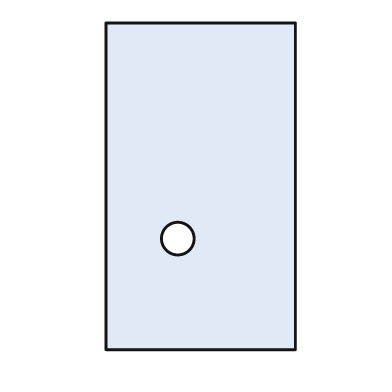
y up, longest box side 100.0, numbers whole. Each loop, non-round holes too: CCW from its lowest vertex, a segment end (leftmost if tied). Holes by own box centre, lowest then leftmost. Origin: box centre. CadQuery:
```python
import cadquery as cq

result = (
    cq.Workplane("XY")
    .moveTo(-29.0, -50.0)
    .lineTo(29.0, -50.0)
    .lineTo(29.0, 50.0)
    .lineTo(-29.0, 50.0)
    .close()
    .moveTo(-7.0, -16.0)
    .circle(5.0)
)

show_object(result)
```